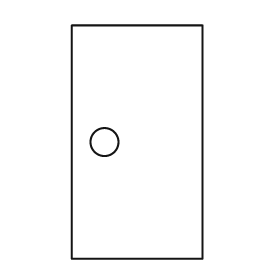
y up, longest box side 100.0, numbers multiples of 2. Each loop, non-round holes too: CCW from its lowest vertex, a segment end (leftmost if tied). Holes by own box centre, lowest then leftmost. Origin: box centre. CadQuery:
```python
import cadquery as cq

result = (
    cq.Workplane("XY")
    .moveTo(-28.0, -50.0)
    .lineTo(28.0, -50.0)
    .lineTo(28.0, 50.0)
    .lineTo(-28.0, 50.0)
    .close()
    .moveTo(-14.0, 0.0)
    .circle(6.0)
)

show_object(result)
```